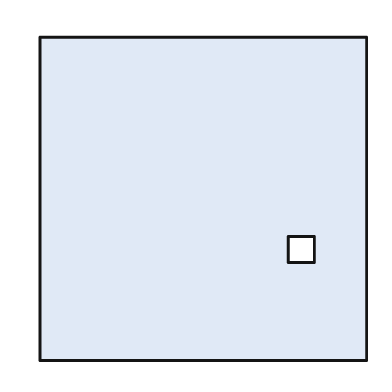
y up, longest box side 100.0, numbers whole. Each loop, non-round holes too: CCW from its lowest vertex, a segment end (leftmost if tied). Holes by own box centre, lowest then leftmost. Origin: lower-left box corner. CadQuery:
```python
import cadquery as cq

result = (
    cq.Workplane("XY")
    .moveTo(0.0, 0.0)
    .lineTo(100.0, 0.0)
    .lineTo(100.0, 99.0)
    .lineTo(0.0, 99.0)
    .close()
    .moveTo(76.0, 30.0)
    .lineTo(84.0, 30.0)
    .lineTo(84.0, 38.0)
    .lineTo(76.0, 38.0)
    .close()
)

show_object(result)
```